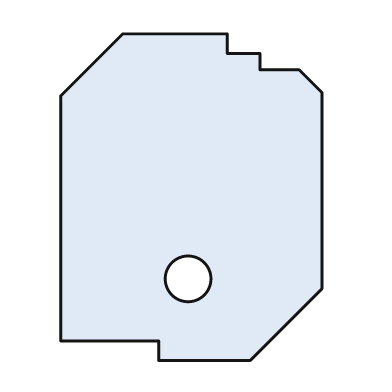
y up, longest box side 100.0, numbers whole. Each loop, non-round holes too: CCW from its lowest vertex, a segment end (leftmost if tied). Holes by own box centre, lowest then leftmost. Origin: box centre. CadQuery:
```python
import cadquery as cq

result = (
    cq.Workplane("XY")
    .moveTo(-10.0, -50.0)
    .lineTo(18.0, -50.0)
    .lineTo(40.0, -28.0)
    .lineTo(40.0, 32.0)
    .lineTo(33.0, 39.0)
    .lineTo(21.0, 39.0)
    .lineTo(21.0, 44.0)
    .lineTo(11.0, 44.0)
    .lineTo(11.0, 50.0)
    .lineTo(-21.0, 50.0)
    .lineTo(-40.0, 31.0)
    .lineTo(-40.0, -44.0)
    .lineTo(-10.0, -44.0)
    .close()
    .moveTo(-1.0, -25.0)
    .circle(7.0)
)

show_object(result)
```